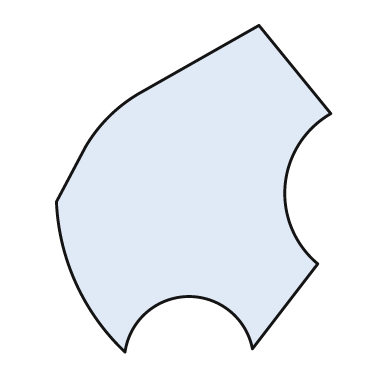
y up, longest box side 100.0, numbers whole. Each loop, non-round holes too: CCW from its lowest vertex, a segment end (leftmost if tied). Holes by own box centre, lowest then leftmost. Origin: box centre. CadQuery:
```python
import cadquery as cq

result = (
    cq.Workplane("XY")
    .moveTo(-21.0, -50.0)
    .threePointArc((-2.0, -33.0), (18.0, -49.0))
    .lineTo(38.0, -23.0)
    .threePointArc((28.0, 1.0), (42.0, 23.0))
    .lineTo(20.0, 50.0)
    .lineTo(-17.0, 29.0)
    .threePointArc((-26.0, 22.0), (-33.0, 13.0))
    .lineTo(-42.0, -4.0)
    .threePointArc((-36.0, -29.0), (-21.0, -50.0))
    .close()
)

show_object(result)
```